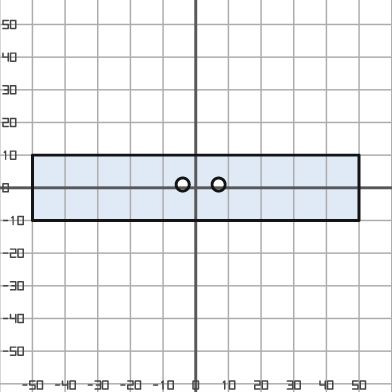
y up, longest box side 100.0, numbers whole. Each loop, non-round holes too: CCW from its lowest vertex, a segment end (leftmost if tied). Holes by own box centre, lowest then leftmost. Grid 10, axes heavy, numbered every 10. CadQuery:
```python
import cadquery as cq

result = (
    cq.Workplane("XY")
    .moveTo(-50.0, -10.0)
    .lineTo(50.0, -10.0)
    .lineTo(50.0, 10.0)
    .lineTo(-50.0, 10.0)
    .close()
    .moveTo(-4.0, 1.0)
    .circle(2.0)
    .moveTo(7.0, 1.0)
    .circle(2.0)
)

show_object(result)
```